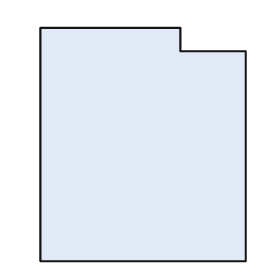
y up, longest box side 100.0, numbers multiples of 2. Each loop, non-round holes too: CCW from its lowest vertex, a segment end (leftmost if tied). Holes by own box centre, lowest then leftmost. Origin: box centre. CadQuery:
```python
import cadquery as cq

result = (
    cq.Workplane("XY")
    .moveTo(-44.0, -50.0)
    .lineTo(44.0, -50.0)
    .lineTo(44.0, 40.0)
    .lineTo(16.0, 40.0)
    .lineTo(16.0, 50.0)
    .lineTo(-44.0, 50.0)
    .close()
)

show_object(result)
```